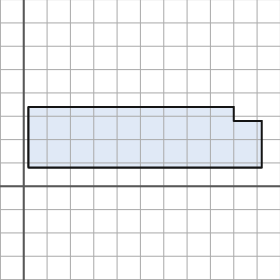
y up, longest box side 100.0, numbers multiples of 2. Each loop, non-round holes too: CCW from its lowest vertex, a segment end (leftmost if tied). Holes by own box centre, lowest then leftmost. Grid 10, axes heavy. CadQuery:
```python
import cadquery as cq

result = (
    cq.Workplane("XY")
    .moveTo(2.0, 8.0)
    .lineTo(102.0, 8.0)
    .lineTo(102.0, 28.0)
    .lineTo(90.0, 28.0)
    .lineTo(90.0, 34.0)
    .lineTo(2.0, 34.0)
    .close()
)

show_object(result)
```